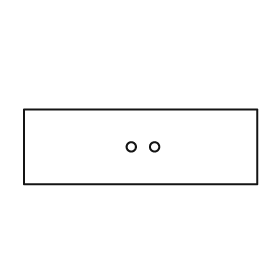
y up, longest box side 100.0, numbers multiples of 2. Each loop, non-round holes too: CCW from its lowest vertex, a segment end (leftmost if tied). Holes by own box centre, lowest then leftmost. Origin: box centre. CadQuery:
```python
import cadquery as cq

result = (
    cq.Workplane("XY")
    .moveTo(-50.0, -16.0)
    .lineTo(50.0, -16.0)
    .lineTo(50.0, 16.0)
    .lineTo(-50.0, 16.0)
    .close()
    .moveTo(-4.0, 0.0)
    .circle(2.0)
    .moveTo(6.0, 0.0)
    .circle(2.0)
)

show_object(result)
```